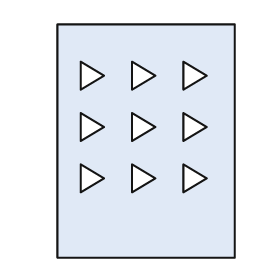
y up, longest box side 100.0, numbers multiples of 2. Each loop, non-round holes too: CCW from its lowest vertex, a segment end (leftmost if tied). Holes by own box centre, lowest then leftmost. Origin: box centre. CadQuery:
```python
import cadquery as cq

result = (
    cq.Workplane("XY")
    .moveTo(-38.0, -50.0)
    .lineTo(38.0, -50.0)
    .lineTo(38.0, 50.0)
    .lineTo(-38.0, 50.0)
    .close()
    .moveTo(-28.0, -22.0)
    .lineTo(-18.0, -16.0)
    .lineTo(-28.0, -10.0)
    .close()
    .moveTo(-6.0, -22.0)
    .lineTo(4.0, -16.0)
    .lineTo(-6.0, -10.0)
    .close()
    .moveTo(16.0, -22.0)
    .lineTo(26.0, -16.0)
    .lineTo(16.0, -10.0)
    .close()
    .moveTo(-28.0, 0.0)
    .lineTo(-18.0, 6.0)
    .lineTo(-28.0, 12.0)
    .close()
    .moveTo(-6.0, 0.0)
    .lineTo(4.0, 6.0)
    .lineTo(-6.0, 12.0)
    .close()
    .moveTo(16.0, 0.0)
    .lineTo(26.0, 6.0)
    .lineTo(16.0, 12.0)
    .close()
    .moveTo(-28.0, 22.0)
    .lineTo(-18.0, 28.0)
    .lineTo(-28.0, 34.0)
    .close()
    .moveTo(-6.0, 22.0)
    .lineTo(4.0, 28.0)
    .lineTo(-6.0, 34.0)
    .close()
    .moveTo(16.0, 22.0)
    .lineTo(26.0, 28.0)
    .lineTo(16.0, 34.0)
    .close()
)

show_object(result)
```